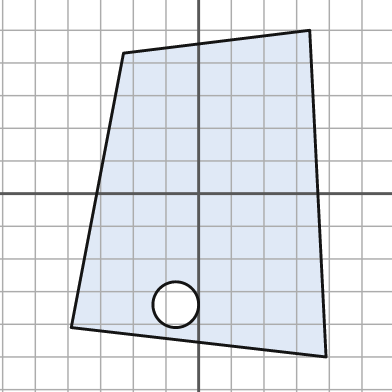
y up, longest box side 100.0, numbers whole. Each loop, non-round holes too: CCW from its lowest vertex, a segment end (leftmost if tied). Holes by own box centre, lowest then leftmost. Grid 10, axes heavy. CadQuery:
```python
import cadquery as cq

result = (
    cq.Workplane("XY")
    .moveTo(39.0, -50.0)
    .lineTo(34.0, 50.0)
    .lineTo(-23.0, 43.0)
    .lineTo(-39.0, -41.0)
    .close()
    .moveTo(-7.0, -34.0)
    .circle(7.0)
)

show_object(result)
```